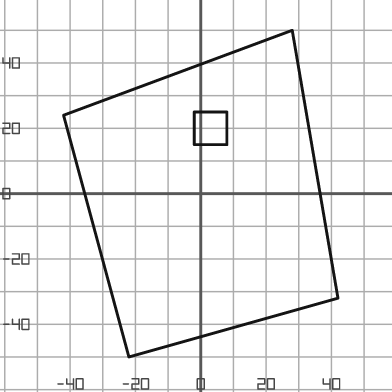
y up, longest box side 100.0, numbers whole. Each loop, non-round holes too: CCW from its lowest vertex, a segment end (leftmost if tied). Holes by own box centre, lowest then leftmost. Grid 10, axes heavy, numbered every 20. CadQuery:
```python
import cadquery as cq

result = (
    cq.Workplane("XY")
    .moveTo(-22.0, -50.0)
    .lineTo(42.0, -32.0)
    .lineTo(28.0, 50.0)
    .lineTo(-42.0, 24.0)
    .close()
    .moveTo(-2.0, 15.0)
    .lineTo(8.0, 15.0)
    .lineTo(8.0, 25.0)
    .lineTo(-2.0, 25.0)
    .close()
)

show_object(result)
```